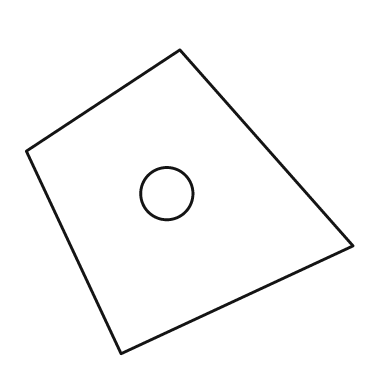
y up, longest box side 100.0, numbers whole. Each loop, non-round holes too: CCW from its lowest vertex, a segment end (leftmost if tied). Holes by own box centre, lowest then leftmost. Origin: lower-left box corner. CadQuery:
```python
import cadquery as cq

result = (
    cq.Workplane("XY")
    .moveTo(29.0, 0.0)
    .lineTo(100.0, 33.0)
    .lineTo(47.0, 93.0)
    .lineTo(0.0, 62.0)
    .close()
    .moveTo(43.0, 49.0)
    .circle(8.0)
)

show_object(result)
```